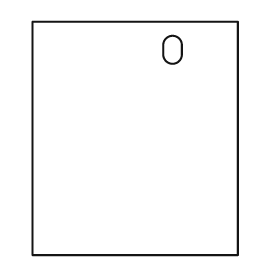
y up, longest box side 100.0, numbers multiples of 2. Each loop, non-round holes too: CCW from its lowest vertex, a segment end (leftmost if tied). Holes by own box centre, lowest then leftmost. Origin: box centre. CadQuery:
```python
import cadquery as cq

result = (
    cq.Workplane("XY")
    .moveTo(-44.0, -50.0)
    .lineTo(44.0, -50.0)
    .lineTo(44.0, 50.0)
    .lineTo(-44.0, 50.0)
    .close()
    .moveTo(12.0, 36.0)
    .threePointArc((16.0, 32.0), (20.0, 36.0))
    .lineTo(20.0, 40.0)
    .threePointArc((16.0, 44.0), (12.0, 40.0))
    .close()
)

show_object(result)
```